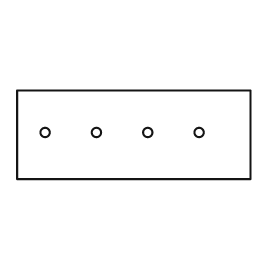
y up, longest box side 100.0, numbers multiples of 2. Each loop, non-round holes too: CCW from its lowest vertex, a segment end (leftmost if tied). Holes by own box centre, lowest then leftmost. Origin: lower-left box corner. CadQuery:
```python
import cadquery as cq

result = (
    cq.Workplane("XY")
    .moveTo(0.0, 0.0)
    .lineTo(100.0, 0.0)
    .lineTo(100.0, 38.0)
    .lineTo(0.0, 38.0)
    .close()
    .moveTo(12.0, 20.0)
    .circle(2.0)
    .moveTo(34.0, 20.0)
    .circle(2.0)
    .moveTo(56.0, 20.0)
    .circle(2.0)
    .moveTo(78.0, 20.0)
    .circle(2.0)
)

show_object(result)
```